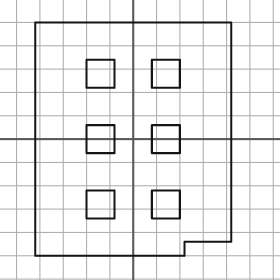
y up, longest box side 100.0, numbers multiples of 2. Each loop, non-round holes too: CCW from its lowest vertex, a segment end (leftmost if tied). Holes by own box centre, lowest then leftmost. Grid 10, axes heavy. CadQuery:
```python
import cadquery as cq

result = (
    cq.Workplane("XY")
    .moveTo(-42.0, -50.0)
    .lineTo(22.0, -50.0)
    .lineTo(22.0, -44.0)
    .lineTo(42.0, -44.0)
    .lineTo(42.0, 50.0)
    .lineTo(-42.0, 50.0)
    .close()
    .moveTo(-20.0, -34.0)
    .lineTo(-8.0, -34.0)
    .lineTo(-8.0, -22.0)
    .lineTo(-20.0, -22.0)
    .close()
    .moveTo(8.0, -34.0)
    .lineTo(20.0, -34.0)
    .lineTo(20.0, -22.0)
    .lineTo(8.0, -22.0)
    .close()
    .moveTo(-20.0, -6.0)
    .lineTo(-8.0, -6.0)
    .lineTo(-8.0, 6.0)
    .lineTo(-20.0, 6.0)
    .close()
    .moveTo(8.0, -6.0)
    .lineTo(20.0, -6.0)
    .lineTo(20.0, 6.0)
    .lineTo(8.0, 6.0)
    .close()
    .moveTo(-20.0, 22.0)
    .lineTo(-8.0, 22.0)
    .lineTo(-8.0, 34.0)
    .lineTo(-20.0, 34.0)
    .close()
    .moveTo(8.0, 22.0)
    .lineTo(20.0, 22.0)
    .lineTo(20.0, 34.0)
    .lineTo(8.0, 34.0)
    .close()
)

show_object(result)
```